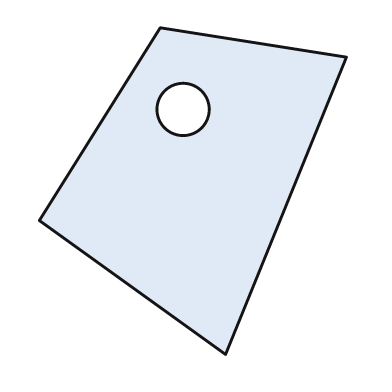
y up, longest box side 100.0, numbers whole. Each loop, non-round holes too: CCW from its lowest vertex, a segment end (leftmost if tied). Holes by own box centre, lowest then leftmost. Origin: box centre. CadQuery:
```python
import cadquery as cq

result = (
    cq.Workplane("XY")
    .moveTo(10.0, -50.0)
    .lineTo(47.0, 41.0)
    .lineTo(-10.0, 50.0)
    .lineTo(-47.0, -9.0)
    .close()
    .moveTo(-3.0, 25.0)
    .circle(8.0)
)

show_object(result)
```